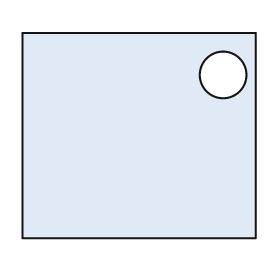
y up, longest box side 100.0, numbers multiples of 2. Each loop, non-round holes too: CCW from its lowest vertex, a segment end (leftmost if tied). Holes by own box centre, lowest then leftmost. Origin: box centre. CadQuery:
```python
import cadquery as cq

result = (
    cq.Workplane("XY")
    .moveTo(-50.0, -44.0)
    .lineTo(50.0, -44.0)
    .lineTo(50.0, 44.0)
    .lineTo(-50.0, 44.0)
    .close()
    .moveTo(36.0, 26.0)
    .circle(10.0)
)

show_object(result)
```